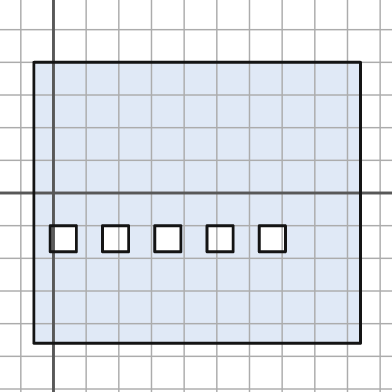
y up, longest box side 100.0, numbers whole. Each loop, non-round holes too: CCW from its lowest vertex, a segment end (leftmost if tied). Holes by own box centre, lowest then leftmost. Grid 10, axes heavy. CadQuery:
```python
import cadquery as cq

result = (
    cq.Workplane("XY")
    .moveTo(-6.0, -46.0)
    .lineTo(94.0, -46.0)
    .lineTo(94.0, 40.0)
    .lineTo(-6.0, 40.0)
    .close()
    .moveTo(-1.0, -18.0)
    .lineTo(7.0, -18.0)
    .lineTo(7.0, -10.0)
    .lineTo(-1.0, -10.0)
    .close()
    .moveTo(15.0, -18.0)
    .lineTo(23.0, -18.0)
    .lineTo(23.0, -10.0)
    .lineTo(15.0, -10.0)
    .close()
    .moveTo(31.0, -18.0)
    .lineTo(39.0, -18.0)
    .lineTo(39.0, -10.0)
    .lineTo(31.0, -10.0)
    .close()
    .moveTo(47.0, -18.0)
    .lineTo(55.0, -18.0)
    .lineTo(55.0, -10.0)
    .lineTo(47.0, -10.0)
    .close()
    .moveTo(63.0, -18.0)
    .lineTo(71.0, -18.0)
    .lineTo(71.0, -10.0)
    .lineTo(63.0, -10.0)
    .close()
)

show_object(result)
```